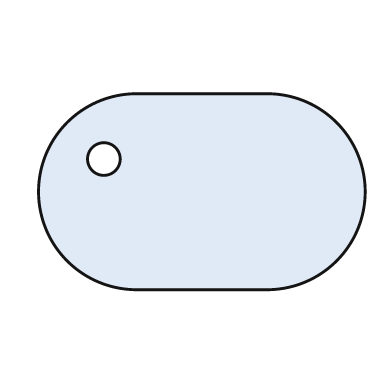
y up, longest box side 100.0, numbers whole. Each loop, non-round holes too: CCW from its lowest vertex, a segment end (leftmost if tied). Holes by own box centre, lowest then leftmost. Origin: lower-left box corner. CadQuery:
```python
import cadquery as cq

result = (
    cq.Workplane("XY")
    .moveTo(30.0, 0.0)
    .lineTo(70.0, 0.0)
    .threePointArc((100.0, 30.0), (70.0, 60.0))
    .lineTo(30.0, 60.0)
    .threePointArc((0.0, 30.0), (30.0, 0.0))
    .close()
    .moveTo(20.0, 40.0)
    .circle(5.0)
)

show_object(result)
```